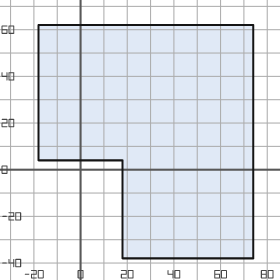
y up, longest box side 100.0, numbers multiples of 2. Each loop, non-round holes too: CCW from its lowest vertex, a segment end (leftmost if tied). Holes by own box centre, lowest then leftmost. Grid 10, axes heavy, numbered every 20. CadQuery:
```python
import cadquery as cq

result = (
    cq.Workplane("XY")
    .moveTo(18.0, -38.0)
    .lineTo(74.0, -38.0)
    .lineTo(74.0, 62.0)
    .lineTo(-18.0, 62.0)
    .lineTo(-18.0, 4.0)
    .lineTo(18.0, 4.0)
    .close()
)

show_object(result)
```